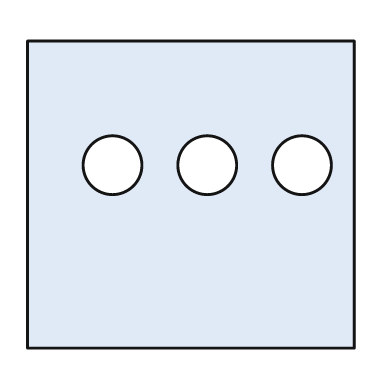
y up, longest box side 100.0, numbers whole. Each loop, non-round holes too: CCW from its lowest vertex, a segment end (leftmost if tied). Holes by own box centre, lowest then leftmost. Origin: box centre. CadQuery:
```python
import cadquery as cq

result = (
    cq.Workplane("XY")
    .moveTo(-50.0, -47.0)
    .lineTo(50.0, -47.0)
    .lineTo(50.0, 47.0)
    .lineTo(-50.0, 47.0)
    .close()
    .moveTo(-24.0, 9.0)
    .circle(9.0)
    .moveTo(5.0, 9.0)
    .circle(9.0)
    .moveTo(34.0, 9.0)
    .circle(9.0)
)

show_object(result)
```